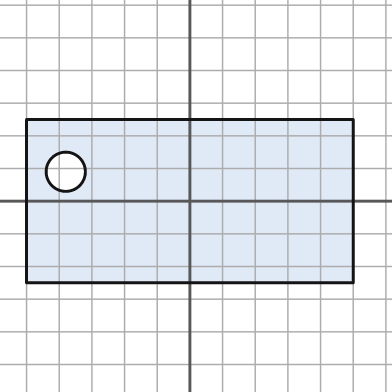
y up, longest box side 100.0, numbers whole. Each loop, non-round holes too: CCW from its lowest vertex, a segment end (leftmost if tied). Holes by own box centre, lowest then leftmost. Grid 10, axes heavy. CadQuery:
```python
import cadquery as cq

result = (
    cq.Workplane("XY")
    .moveTo(-50.0, -25.0)
    .lineTo(50.0, -25.0)
    .lineTo(50.0, 25.0)
    .lineTo(-50.0, 25.0)
    .close()
    .moveTo(-38.0, 9.0)
    .circle(6.0)
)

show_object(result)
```